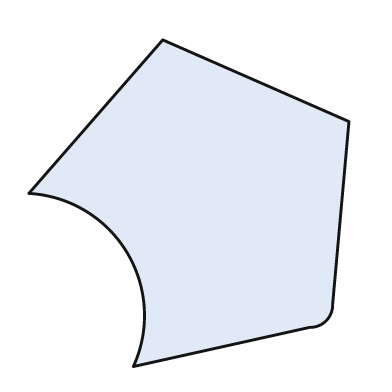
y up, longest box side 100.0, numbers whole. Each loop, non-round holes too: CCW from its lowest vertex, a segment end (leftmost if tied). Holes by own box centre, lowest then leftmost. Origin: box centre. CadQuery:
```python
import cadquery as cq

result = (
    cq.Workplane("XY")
    .moveTo(-17.0, -50.0)
    .lineTo(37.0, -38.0)
    .threePointArc((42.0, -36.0), (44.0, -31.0))
    .lineTo(49.0, 25.0)
    .lineTo(-8.0, 50.0)
    .lineTo(-49.0, 3.0)
    .threePointArc((-19.0, -15.0), (-17.0, -50.0))
    .close()
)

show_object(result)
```